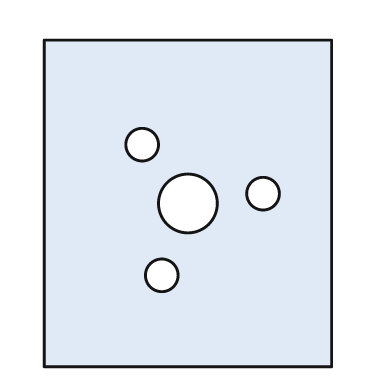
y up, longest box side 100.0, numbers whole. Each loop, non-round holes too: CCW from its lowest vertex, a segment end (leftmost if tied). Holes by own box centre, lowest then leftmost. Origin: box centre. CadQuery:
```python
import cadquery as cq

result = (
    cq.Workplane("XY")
    .moveTo(-44.0, -50.0)
    .lineTo(44.0, -50.0)
    .lineTo(44.0, 50.0)
    .lineTo(-44.0, 50.0)
    .close()
    .moveTo(-8.0, -22.0)
    .circle(5.0)
    .moveTo(0.0, 0.0)
    .circle(9.0)
    .moveTo(23.0, 3.0)
    .circle(5.0)
    .moveTo(-14.0, 18.0)
    .circle(5.0)
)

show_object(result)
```